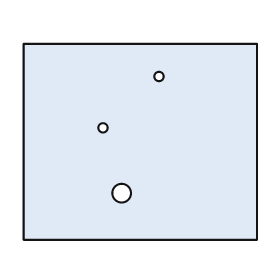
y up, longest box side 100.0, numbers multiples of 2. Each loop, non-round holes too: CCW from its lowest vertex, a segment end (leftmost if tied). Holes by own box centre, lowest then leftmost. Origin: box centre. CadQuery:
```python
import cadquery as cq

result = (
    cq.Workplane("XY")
    .moveTo(-50.0, -42.0)
    .lineTo(50.0, -42.0)
    .lineTo(50.0, 42.0)
    .lineTo(-50.0, 42.0)
    .close()
    .moveTo(-8.0, -22.0)
    .circle(4.0)
    .moveTo(-16.0, 6.0)
    .circle(2.0)
    .moveTo(8.0, 28.0)
    .circle(2.0)
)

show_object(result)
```